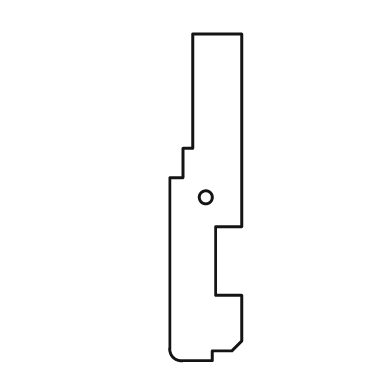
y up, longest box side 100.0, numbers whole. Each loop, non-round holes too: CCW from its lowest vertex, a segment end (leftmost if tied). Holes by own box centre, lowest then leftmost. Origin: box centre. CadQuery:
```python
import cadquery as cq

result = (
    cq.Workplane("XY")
    .moveTo(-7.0, -50.0)
    .lineTo(2.0, -50.0)
    .lineTo(2.0, -47.0)
    .lineTo(8.0, -47.0)
    .lineTo(11.0, -44.0)
    .lineTo(11.0, -30.0)
    .lineTo(3.0, -30.0)
    .lineTo(3.0, -9.0)
    .lineTo(11.0, -9.0)
    .lineTo(11.0, 50.0)
    .lineTo(-4.0, 50.0)
    .lineTo(-4.0, 15.0)
    .lineTo(-7.0, 15.0)
    .lineTo(-7.0, 6.0)
    .lineTo(-11.0, 6.0)
    .lineTo(-11.0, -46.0)
    .threePointArc((-10.0, -49.0), (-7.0, -50.0))
    .close()
    .moveTo(0.0, 0.0)
    .circle(2.0)
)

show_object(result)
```